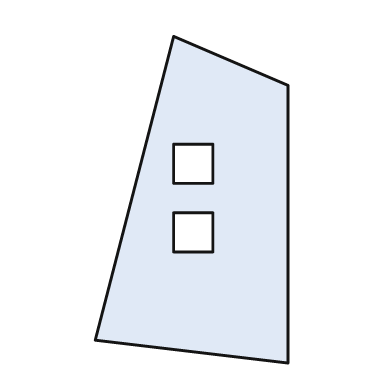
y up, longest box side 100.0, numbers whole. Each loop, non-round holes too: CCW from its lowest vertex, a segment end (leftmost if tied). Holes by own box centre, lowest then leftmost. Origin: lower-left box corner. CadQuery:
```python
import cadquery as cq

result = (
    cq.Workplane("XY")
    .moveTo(59.0, 0.0)
    .lineTo(59.0, 85.0)
    .lineTo(24.0, 100.0)
    .lineTo(0.0, 7.0)
    .close()
    .moveTo(24.0, 34.0)
    .lineTo(36.0, 34.0)
    .lineTo(36.0, 46.0)
    .lineTo(24.0, 46.0)
    .close()
    .moveTo(24.0, 55.0)
    .lineTo(36.0, 55.0)
    .lineTo(36.0, 67.0)
    .lineTo(24.0, 67.0)
    .close()
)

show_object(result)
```